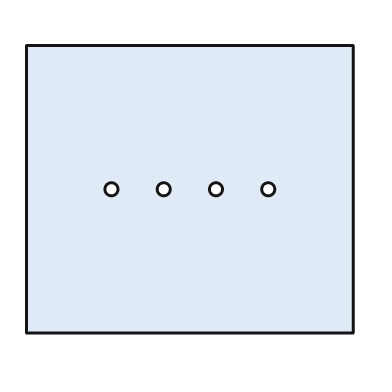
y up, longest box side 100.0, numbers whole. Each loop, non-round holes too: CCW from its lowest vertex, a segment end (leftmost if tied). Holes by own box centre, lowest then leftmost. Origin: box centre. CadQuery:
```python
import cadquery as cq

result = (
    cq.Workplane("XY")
    .moveTo(-50.0, -44.0)
    .lineTo(50.0, -44.0)
    .lineTo(50.0, 44.0)
    .lineTo(-50.0, 44.0)
    .close()
    .moveTo(-24.0, 0.0)
    .circle(2.0)
    .moveTo(-8.0, 0.0)
    .circle(2.0)
    .moveTo(8.0, 0.0)
    .circle(2.0)
    .moveTo(24.0, 0.0)
    .circle(2.0)
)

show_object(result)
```